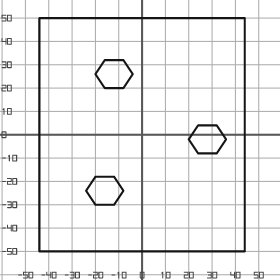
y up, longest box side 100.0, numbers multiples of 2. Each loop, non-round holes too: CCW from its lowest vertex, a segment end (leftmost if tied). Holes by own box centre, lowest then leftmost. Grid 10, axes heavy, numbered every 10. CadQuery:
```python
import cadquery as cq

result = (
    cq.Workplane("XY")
    .moveTo(-44.0, -50.0)
    .lineTo(44.0, -50.0)
    .lineTo(44.0, 50.0)
    .lineTo(-44.0, 50.0)
    .close()
    .moveTo(-20.0, -30.0)
    .lineTo(-12.0, -30.0)
    .lineTo(-8.0, -24.0)
    .lineTo(-12.0, -18.0)
    .lineTo(-20.0, -18.0)
    .lineTo(-24.0, -24.0)
    .close()
    .moveTo(24.0, -8.0)
    .lineTo(32.0, -8.0)
    .lineTo(36.0, -2.0)
    .lineTo(32.0, 4.0)
    .lineTo(24.0, 4.0)
    .lineTo(20.0, -2.0)
    .close()
    .moveTo(-16.0, 20.0)
    .lineTo(-8.0, 20.0)
    .lineTo(-4.0, 26.0)
    .lineTo(-8.0, 32.0)
    .lineTo(-16.0, 32.0)
    .lineTo(-20.0, 26.0)
    .close()
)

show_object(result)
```